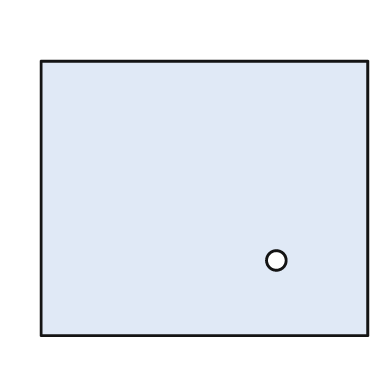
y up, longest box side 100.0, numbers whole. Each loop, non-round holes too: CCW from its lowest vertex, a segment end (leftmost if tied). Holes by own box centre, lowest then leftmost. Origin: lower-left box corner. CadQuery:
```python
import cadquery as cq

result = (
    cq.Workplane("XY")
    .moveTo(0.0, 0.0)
    .lineTo(100.0, 0.0)
    .lineTo(100.0, 84.0)
    .lineTo(0.0, 84.0)
    .close()
    .moveTo(72.0, 23.0)
    .circle(3.0)
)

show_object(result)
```